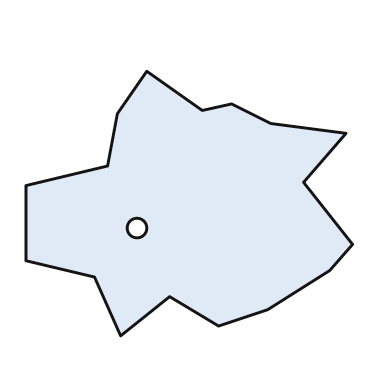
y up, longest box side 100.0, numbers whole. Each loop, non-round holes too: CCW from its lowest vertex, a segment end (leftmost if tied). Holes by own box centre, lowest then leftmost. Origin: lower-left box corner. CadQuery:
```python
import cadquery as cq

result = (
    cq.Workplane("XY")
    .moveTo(29.0, 0.0)
    .lineTo(44.0, 12.0)
    .lineTo(59.0, 3.0)
    .lineTo(74.0, 8.0)
    .lineTo(93.0, 20.0)
    .lineTo(100.0, 28.0)
    .lineTo(85.0, 47.0)
    .lineTo(98.0, 62.0)
    .lineTo(75.0, 65.0)
    .lineTo(63.0, 71.0)
    .lineTo(54.0, 69.0)
    .lineTo(37.0, 81.0)
    .lineTo(28.0, 68.0)
    .lineTo(25.0, 52.0)
    .lineTo(0.0, 46.0)
    .lineTo(0.0, 23.0)
    .lineTo(21.0, 18.0)
    .close()
    .moveTo(34.0, 33.0)
    .circle(3.0)
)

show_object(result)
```